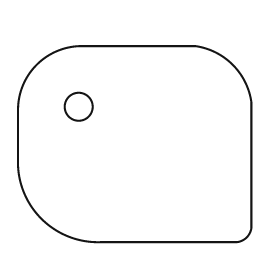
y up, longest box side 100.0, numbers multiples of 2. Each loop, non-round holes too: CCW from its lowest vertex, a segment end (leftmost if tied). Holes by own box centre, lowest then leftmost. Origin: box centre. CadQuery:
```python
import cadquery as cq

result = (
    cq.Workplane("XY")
    .moveTo(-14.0, -42.0)
    .lineTo(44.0, -42.0)
    .threePointArc((48.0, -40.0), (50.0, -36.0))
    .lineTo(50.0, 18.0)
    .threePointArc((42.0, 34.0), (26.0, 42.0))
    .lineTo(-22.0, 42.0)
    .threePointArc((-42.0, 34.0), (-50.0, 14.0))
    .lineTo(-50.0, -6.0)
    .threePointArc((-40.0, -32.0), (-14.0, -42.0))
    .close()
    .moveTo(-24.0, 16.0)
    .circle(6.0)
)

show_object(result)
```